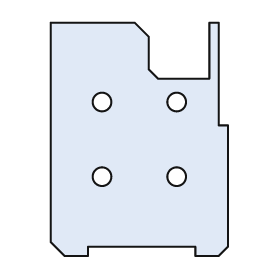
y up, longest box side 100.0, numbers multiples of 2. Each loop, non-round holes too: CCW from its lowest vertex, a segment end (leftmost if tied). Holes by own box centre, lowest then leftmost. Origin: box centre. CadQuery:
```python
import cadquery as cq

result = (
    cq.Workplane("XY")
    .moveTo(-32.0, -50.0)
    .lineTo(-22.0, -50.0)
    .lineTo(-22.0, -46.0)
    .lineTo(24.0, -46.0)
    .lineTo(24.0, -50.0)
    .lineTo(34.0, -50.0)
    .lineTo(38.0, -46.0)
    .lineTo(38.0, 6.0)
    .lineTo(34.0, 6.0)
    .lineTo(34.0, 50.0)
    .lineTo(30.0, 50.0)
    .lineTo(30.0, 26.0)
    .lineTo(8.0, 26.0)
    .lineTo(4.0, 30.0)
    .lineTo(4.0, 44.0)
    .lineTo(-2.0, 50.0)
    .lineTo(-38.0, 50.0)
    .lineTo(-38.0, -44.0)
    .close()
    .moveTo(-16.0, -16.0)
    .circle(4.0)
    .moveTo(16.0, -16.0)
    .circle(4.0)
    .moveTo(-16.0, 16.0)
    .circle(4.0)
    .moveTo(16.0, 16.0)
    .circle(4.0)
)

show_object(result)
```